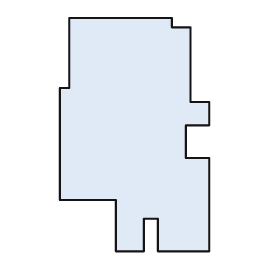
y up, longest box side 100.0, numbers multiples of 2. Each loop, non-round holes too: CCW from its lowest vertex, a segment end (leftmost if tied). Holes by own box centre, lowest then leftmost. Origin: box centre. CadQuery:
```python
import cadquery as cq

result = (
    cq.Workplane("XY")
    .moveTo(-8.0, -50.0)
    .lineTo(4.0, -50.0)
    .lineTo(4.0, -36.0)
    .lineTo(10.0, -36.0)
    .lineTo(10.0, -50.0)
    .lineTo(32.0, -50.0)
    .lineTo(32.0, -10.0)
    .lineTo(22.0, -10.0)
    .lineTo(22.0, 4.0)
    .lineTo(32.0, 4.0)
    .lineTo(32.0, 14.0)
    .lineTo(24.0, 14.0)
    .lineTo(24.0, 46.0)
    .lineTo(16.0, 46.0)
    .lineTo(16.0, 50.0)
    .lineTo(-28.0, 50.0)
    .lineTo(-28.0, 20.0)
    .lineTo(-32.0, 20.0)
    .lineTo(-32.0, -28.0)
    .lineTo(-8.0, -28.0)
    .close()
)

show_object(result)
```